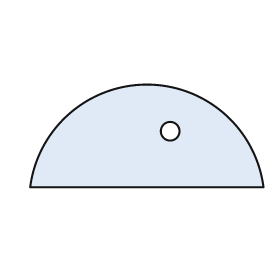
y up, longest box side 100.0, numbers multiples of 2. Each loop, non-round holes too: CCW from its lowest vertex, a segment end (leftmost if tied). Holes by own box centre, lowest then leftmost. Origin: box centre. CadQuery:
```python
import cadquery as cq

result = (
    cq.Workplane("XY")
    .moveTo(-50.0, -22.0)
    .lineTo(50.0, -22.0)
    .threePointArc((0.0, 22.0), (-50.0, -22.0))
    .close()
    .moveTo(10.0, 2.0)
    .circle(4.0)
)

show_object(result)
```